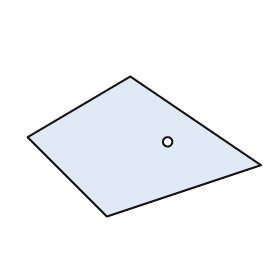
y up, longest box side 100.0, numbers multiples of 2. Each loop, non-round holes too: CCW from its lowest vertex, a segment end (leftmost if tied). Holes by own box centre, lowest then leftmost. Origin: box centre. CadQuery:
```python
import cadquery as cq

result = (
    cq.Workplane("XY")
    .moveTo(-16.0, -30.0)
    .lineTo(50.0, -8.0)
    .lineTo(-6.0, 30.0)
    .lineTo(-50.0, 4.0)
    .close()
    .moveTo(10.0, 2.0)
    .circle(2.0)
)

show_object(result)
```